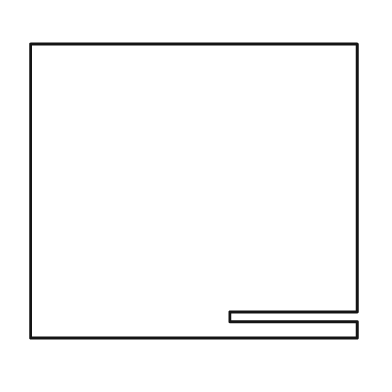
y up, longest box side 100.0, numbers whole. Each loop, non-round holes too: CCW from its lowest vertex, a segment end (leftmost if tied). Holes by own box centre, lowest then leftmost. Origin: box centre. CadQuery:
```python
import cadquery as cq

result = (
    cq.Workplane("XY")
    .moveTo(-50.0, -45.0)
    .lineTo(50.0, -45.0)
    .lineTo(50.0, -40.0)
    .lineTo(11.0, -40.0)
    .lineTo(11.0, -37.0)
    .lineTo(50.0, -37.0)
    .lineTo(50.0, 45.0)
    .lineTo(-50.0, 45.0)
    .close()
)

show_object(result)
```